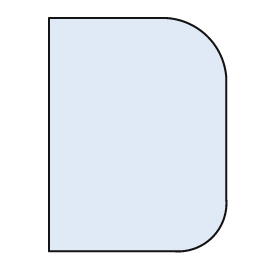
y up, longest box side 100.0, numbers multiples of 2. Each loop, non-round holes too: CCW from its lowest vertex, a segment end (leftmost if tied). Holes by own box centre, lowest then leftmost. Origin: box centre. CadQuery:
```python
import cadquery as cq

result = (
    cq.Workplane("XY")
    .moveTo(-38.0, -50.0)
    .lineTo(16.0, -50.0)
    .threePointArc((32.0, -44.0), (38.0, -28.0))
    .lineTo(38.0, 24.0)
    .threePointArc((30.0, 42.0), (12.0, 50.0))
    .lineTo(-38.0, 50.0)
    .close()
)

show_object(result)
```